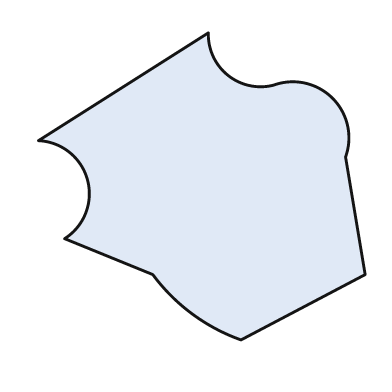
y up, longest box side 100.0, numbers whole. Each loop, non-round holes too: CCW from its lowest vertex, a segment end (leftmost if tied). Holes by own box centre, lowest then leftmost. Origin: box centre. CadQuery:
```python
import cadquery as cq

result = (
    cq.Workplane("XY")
    .moveTo(12.0, -47.0)
    .lineTo(50.0, -27.0)
    .lineTo(44.0, 9.0)
    .threePointArc((40.0, 27.0), (22.0, 31.0))
    .threePointArc((8.0, 34.0), (2.0, 47.0))
    .lineTo(-50.0, 14.0)
    .threePointArc((-35.0, 2.0), (-42.0, -16.0))
    .lineTo(-15.0, -27.0)
    .threePointArc((-3.0, -39.0), (12.0, -47.0))
    .close()
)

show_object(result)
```